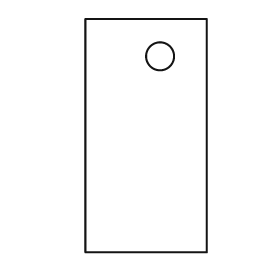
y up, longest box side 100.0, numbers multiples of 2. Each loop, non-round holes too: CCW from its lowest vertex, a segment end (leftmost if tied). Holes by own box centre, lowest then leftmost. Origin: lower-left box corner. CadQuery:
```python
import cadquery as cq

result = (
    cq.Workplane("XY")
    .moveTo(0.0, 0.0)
    .lineTo(52.0, 0.0)
    .lineTo(52.0, 100.0)
    .lineTo(0.0, 100.0)
    .close()
    .moveTo(32.0, 84.0)
    .circle(6.0)
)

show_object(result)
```